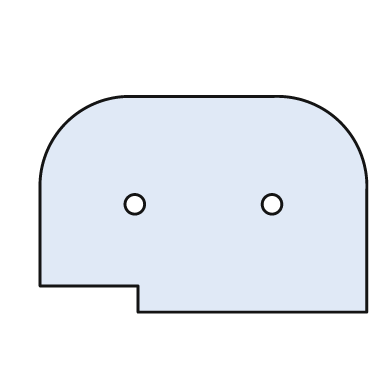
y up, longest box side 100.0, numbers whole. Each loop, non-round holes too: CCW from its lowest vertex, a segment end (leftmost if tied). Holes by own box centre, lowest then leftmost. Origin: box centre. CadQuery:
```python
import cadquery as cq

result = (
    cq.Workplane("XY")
    .moveTo(-20.0, -33.0)
    .lineTo(50.0, -33.0)
    .lineTo(50.0, 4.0)
    .threePointArc((42.0, 25.0), (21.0, 33.0))
    .lineTo(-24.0, 33.0)
    .threePointArc((-42.0, 25.0), (-50.0, 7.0))
    .lineTo(-50.0, -25.0)
    .lineTo(-20.0, -25.0)
    .close()
    .moveTo(-21.0, 0.0)
    .circle(3.0)
    .moveTo(21.0, 0.0)
    .circle(3.0)
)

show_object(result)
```